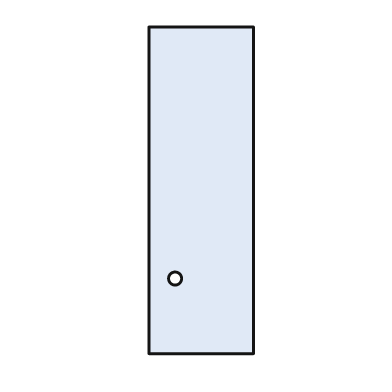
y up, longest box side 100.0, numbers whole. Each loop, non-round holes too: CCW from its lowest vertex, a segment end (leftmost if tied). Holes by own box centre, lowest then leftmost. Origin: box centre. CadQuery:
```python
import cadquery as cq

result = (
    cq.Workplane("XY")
    .moveTo(-16.0, -50.0)
    .lineTo(16.0, -50.0)
    .lineTo(16.0, 50.0)
    .lineTo(-16.0, 50.0)
    .close()
    .moveTo(-8.0, -27.0)
    .circle(2.0)
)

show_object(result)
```